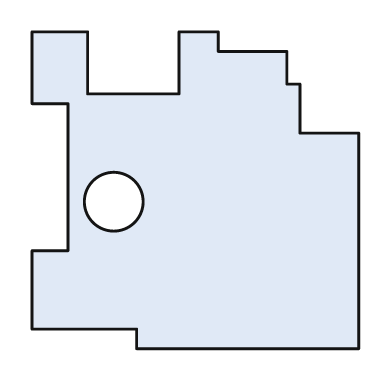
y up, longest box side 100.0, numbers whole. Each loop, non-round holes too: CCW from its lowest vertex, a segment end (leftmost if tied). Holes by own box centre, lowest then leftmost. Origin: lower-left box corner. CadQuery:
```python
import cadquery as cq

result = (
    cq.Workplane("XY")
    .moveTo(32.0, 0.0)
    .lineTo(100.0, 0.0)
    .lineTo(100.0, 66.0)
    .lineTo(82.0, 66.0)
    .lineTo(82.0, 81.0)
    .lineTo(78.0, 81.0)
    .lineTo(78.0, 91.0)
    .lineTo(57.0, 91.0)
    .lineTo(57.0, 97.0)
    .lineTo(45.0, 97.0)
    .lineTo(45.0, 78.0)
    .lineTo(17.0, 78.0)
    .lineTo(17.0, 97.0)
    .lineTo(0.0, 97.0)
    .lineTo(0.0, 75.0)
    .lineTo(11.0, 75.0)
    .lineTo(11.0, 30.0)
    .lineTo(0.0, 30.0)
    .lineTo(0.0, 6.0)
    .lineTo(32.0, 6.0)
    .close()
    .moveTo(25.0, 45.0)
    .circle(9.0)
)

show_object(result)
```